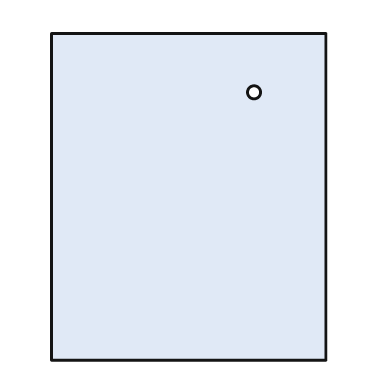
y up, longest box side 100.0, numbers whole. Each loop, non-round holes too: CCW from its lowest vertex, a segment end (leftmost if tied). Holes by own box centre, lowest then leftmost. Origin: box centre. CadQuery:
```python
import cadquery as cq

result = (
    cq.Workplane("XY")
    .moveTo(-42.0, -50.0)
    .lineTo(42.0, -50.0)
    .lineTo(42.0, 50.0)
    .lineTo(-42.0, 50.0)
    .close()
    .moveTo(20.0, 32.0)
    .circle(2.0)
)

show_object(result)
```